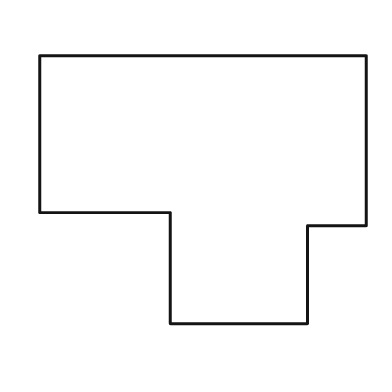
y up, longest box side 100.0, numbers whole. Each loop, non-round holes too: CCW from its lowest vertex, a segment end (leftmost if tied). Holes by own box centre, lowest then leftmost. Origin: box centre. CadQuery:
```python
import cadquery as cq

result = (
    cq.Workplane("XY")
    .moveTo(-10.0, -41.0)
    .lineTo(32.0, -41.0)
    .lineTo(32.0, -11.0)
    .lineTo(50.0, -11.0)
    .lineTo(50.0, 41.0)
    .lineTo(-50.0, 41.0)
    .lineTo(-50.0, -7.0)
    .lineTo(-10.0, -7.0)
    .close()
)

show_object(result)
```